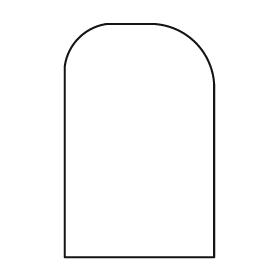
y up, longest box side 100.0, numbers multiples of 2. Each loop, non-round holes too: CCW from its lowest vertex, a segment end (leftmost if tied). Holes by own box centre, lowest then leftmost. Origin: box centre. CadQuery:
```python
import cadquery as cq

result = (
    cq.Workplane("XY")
    .moveTo(-32.0, -50.0)
    .lineTo(32.0, -50.0)
    .lineTo(32.0, 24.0)
    .threePointArc((24.0, 42.0), (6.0, 50.0))
    .lineTo(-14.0, 50.0)
    .threePointArc((-26.0, 44.0), (-32.0, 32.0))
    .close()
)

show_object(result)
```